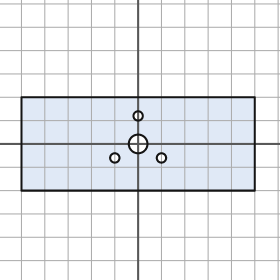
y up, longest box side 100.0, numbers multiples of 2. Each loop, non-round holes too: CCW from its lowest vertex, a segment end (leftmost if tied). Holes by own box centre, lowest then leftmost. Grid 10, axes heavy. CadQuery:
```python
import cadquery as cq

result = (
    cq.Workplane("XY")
    .moveTo(-50.0, -20.0)
    .lineTo(50.0, -20.0)
    .lineTo(50.0, 20.0)
    .lineTo(-50.0, 20.0)
    .close()
    .moveTo(-10.0, -6.0)
    .circle(2.0)
    .moveTo(10.0, -6.0)
    .circle(2.0)
    .moveTo(0.0, 0.0)
    .circle(4.0)
    .moveTo(0.0, 12.0)
    .circle(2.0)
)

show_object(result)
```